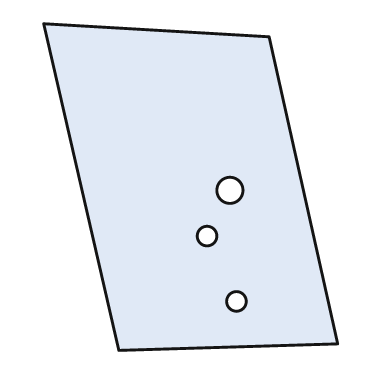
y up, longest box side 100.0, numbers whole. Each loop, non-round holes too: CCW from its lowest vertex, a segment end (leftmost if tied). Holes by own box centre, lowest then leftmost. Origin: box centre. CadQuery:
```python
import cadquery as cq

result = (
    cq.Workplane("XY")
    .moveTo(-22.0, -50.0)
    .lineTo(45.0, -48.0)
    .lineTo(24.0, 46.0)
    .lineTo(-45.0, 50.0)
    .close()
    .moveTo(14.0, -35.0)
    .circle(3.0)
    .moveTo(5.0, -15.0)
    .circle(3.0)
    .moveTo(12.0, -1.0)
    .circle(4.0)
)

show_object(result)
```